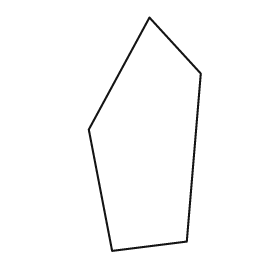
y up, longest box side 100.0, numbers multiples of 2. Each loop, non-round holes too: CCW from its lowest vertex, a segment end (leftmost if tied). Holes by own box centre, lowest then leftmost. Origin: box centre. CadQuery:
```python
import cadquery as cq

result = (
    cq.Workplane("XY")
    .moveTo(-14.0, -50.0)
    .lineTo(18.0, -46.0)
    .lineTo(24.0, 26.0)
    .lineTo(2.0, 50.0)
    .lineTo(-24.0, 2.0)
    .close()
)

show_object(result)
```